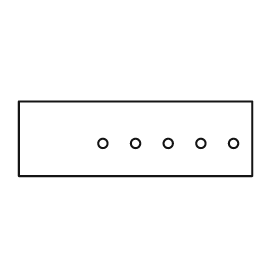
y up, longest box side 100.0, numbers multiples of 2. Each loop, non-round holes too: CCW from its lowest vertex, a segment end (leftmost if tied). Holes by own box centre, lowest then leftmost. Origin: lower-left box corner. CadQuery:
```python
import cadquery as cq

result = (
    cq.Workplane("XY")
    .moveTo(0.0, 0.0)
    .lineTo(100.0, 0.0)
    .lineTo(100.0, 32.0)
    .lineTo(0.0, 32.0)
    .close()
    .moveTo(36.0, 14.0)
    .circle(2.0)
    .moveTo(50.0, 14.0)
    .circle(2.0)
    .moveTo(64.0, 14.0)
    .circle(2.0)
    .moveTo(78.0, 14.0)
    .circle(2.0)
    .moveTo(92.0, 14.0)
    .circle(2.0)
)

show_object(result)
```